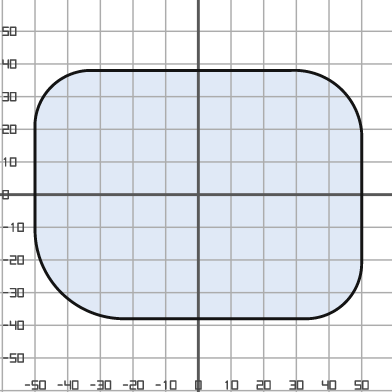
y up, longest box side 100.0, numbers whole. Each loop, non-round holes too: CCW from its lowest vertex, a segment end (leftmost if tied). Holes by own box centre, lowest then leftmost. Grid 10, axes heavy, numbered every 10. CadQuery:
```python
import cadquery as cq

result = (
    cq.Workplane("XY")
    .moveTo(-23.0, -38.0)
    .lineTo(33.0, -38.0)
    .threePointArc((45.0, -33.0), (50.0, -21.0))
    .lineTo(50.0, 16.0)
    .threePointArc((44.0, 32.0), (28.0, 38.0))
    .lineTo(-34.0, 38.0)
    .threePointArc((-45.0, 33.0), (-50.0, 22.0))
    .lineTo(-50.0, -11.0)
    .threePointArc((-42.0, -30.0), (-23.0, -38.0))
    .close()
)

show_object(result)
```